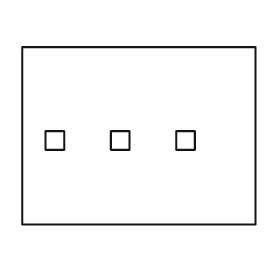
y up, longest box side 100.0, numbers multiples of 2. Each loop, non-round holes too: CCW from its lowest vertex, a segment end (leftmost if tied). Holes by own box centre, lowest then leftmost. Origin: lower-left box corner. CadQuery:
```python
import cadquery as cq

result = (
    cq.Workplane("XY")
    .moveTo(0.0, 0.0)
    .lineTo(100.0, 0.0)
    .lineTo(100.0, 76.0)
    .lineTo(0.0, 76.0)
    .close()
    .moveTo(10.0, 32.0)
    .lineTo(18.0, 32.0)
    .lineTo(18.0, 40.0)
    .lineTo(10.0, 40.0)
    .close()
    .moveTo(38.0, 32.0)
    .lineTo(46.0, 32.0)
    .lineTo(46.0, 40.0)
    .lineTo(38.0, 40.0)
    .close()
    .moveTo(66.0, 32.0)
    .lineTo(74.0, 32.0)
    .lineTo(74.0, 40.0)
    .lineTo(66.0, 40.0)
    .close()
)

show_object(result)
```